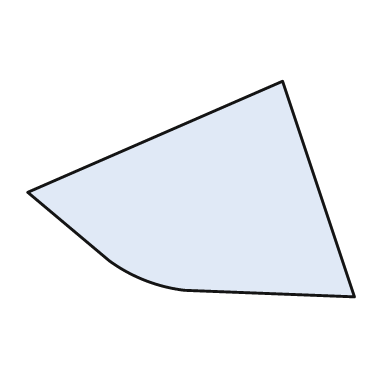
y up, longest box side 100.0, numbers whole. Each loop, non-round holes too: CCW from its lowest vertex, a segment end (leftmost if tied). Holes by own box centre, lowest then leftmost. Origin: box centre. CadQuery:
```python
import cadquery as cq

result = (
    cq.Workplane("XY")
    .moveTo(50.0, -33.0)
    .lineTo(28.0, 33.0)
    .lineTo(-50.0, -1.0)
    .lineTo(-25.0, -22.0)
    .threePointArc((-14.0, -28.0), (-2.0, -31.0))
    .close()
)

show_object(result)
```